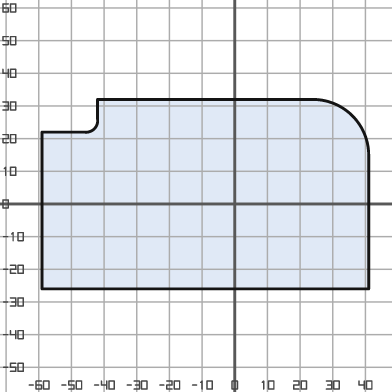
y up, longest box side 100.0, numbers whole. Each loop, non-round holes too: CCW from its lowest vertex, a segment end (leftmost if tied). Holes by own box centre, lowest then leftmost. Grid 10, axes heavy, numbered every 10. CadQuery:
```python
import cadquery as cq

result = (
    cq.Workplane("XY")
    .moveTo(-59.0, -26.0)
    .lineTo(41.0, -26.0)
    .lineTo(41.0, 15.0)
    .threePointArc((36.0, 27.0), (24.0, 32.0))
    .lineTo(-42.0, 32.0)
    .lineTo(-42.0, 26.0)
    .threePointArc((-43.0, 23.0), (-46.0, 22.0))
    .lineTo(-59.0, 22.0)
    .close()
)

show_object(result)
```